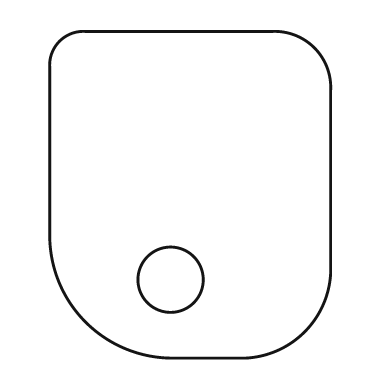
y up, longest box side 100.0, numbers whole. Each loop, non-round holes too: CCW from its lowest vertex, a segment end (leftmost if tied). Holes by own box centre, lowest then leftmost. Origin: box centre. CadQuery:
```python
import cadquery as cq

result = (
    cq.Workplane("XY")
    .moveTo(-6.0, -50.0)
    .lineTo(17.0, -50.0)
    .threePointArc((35.0, -42.0), (43.0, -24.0))
    .lineTo(43.0, 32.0)
    .threePointArc((38.0, 45.0), (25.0, 50.0))
    .lineTo(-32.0, 50.0)
    .threePointArc((-40.0, 47.0), (-43.0, 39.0))
    .lineTo(-43.0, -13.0)
    .threePointArc((-32.0, -39.0), (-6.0, -50.0))
    .close()
    .moveTo(-6.0, -26.0)
    .circle(10.0)
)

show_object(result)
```